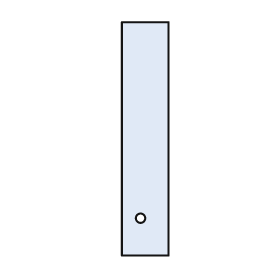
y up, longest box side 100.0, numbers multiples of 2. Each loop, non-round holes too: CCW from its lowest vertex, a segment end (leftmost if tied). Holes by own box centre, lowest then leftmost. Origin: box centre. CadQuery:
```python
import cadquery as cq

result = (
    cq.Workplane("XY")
    .moveTo(-10.0, -50.0)
    .lineTo(10.0, -50.0)
    .lineTo(10.0, 50.0)
    .lineTo(-10.0, 50.0)
    .close()
    .moveTo(-2.0, -34.0)
    .circle(2.0)
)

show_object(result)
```